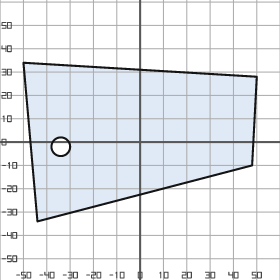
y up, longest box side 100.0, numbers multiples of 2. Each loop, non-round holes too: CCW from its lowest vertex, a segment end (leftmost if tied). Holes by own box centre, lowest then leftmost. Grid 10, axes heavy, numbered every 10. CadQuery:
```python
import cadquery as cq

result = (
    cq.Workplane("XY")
    .moveTo(-44.0, -34.0)
    .lineTo(48.0, -10.0)
    .lineTo(50.0, 28.0)
    .lineTo(-50.0, 34.0)
    .close()
    .moveTo(-34.0, -2.0)
    .circle(4.0)
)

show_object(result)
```